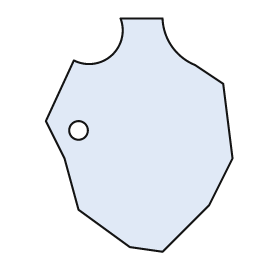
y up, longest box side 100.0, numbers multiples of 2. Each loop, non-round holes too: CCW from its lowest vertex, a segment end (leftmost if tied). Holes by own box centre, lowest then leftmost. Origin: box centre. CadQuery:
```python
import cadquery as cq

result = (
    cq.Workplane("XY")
    .moveTo(10.0, -50.0)
    .lineTo(30.0, -30.0)
    .lineTo(40.0, -10.0)
    .lineTo(36.0, 22.0)
    .lineTo(24.0, 30.0)
    .threePointArc((14.0, 38.0), (10.0, 50.0))
    .lineTo(-8.0, 50.0)
    .threePointArc((-12.0, 34.0), (-28.0, 32.0))
    .lineTo(-40.0, 6.0)
    .lineTo(-32.0, -10.0)
    .lineTo(-26.0, -32.0)
    .lineTo(-4.0, -48.0)
    .close()
    .moveTo(-26.0, 2.0)
    .circle(4.0)
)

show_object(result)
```